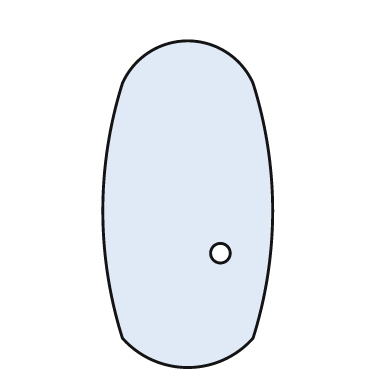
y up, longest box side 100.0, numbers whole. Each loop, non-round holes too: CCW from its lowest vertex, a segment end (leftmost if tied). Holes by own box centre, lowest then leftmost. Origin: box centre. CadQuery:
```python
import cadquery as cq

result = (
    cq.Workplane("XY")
    .moveTo(-20.0, -41.0)
    .threePointArc((0.0, -50.0), (20.0, -41.0))
    .threePointArc((26.0, -2.0), (20.0, 37.0))
    .threePointArc((0.0, 50.0), (-20.0, 37.0))
    .threePointArc((-26.0, -2.0), (-20.0, -41.0))
    .close()
    .moveTo(10.0, -15.0)
    .circle(3.0)
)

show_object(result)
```